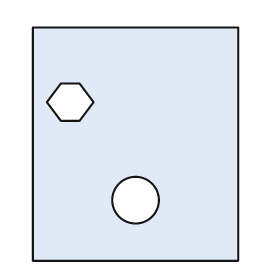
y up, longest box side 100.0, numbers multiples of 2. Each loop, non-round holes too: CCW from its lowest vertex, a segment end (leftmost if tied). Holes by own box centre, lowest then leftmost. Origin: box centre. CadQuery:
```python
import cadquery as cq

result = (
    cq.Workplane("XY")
    .moveTo(-44.0, -50.0)
    .lineTo(44.0, -50.0)
    .lineTo(44.0, 50.0)
    .lineTo(-44.0, 50.0)
    .close()
    .moveTo(0.0, -24.0)
    .circle(10.0)
    .moveTo(-32.0, 10.0)
    .lineTo(-24.0, 10.0)
    .lineTo(-18.0, 18.0)
    .lineTo(-24.0, 26.0)
    .lineTo(-32.0, 26.0)
    .lineTo(-38.0, 18.0)
    .close()
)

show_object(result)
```